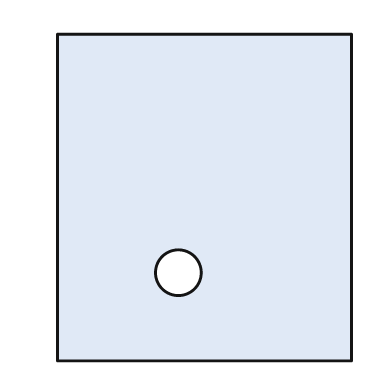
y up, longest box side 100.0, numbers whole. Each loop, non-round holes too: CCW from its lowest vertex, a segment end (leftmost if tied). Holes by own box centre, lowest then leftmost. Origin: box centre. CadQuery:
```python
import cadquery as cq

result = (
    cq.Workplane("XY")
    .moveTo(-45.0, -50.0)
    .lineTo(45.0, -50.0)
    .lineTo(45.0, 50.0)
    .lineTo(-45.0, 50.0)
    .close()
    .moveTo(-8.0, -23.0)
    .circle(7.0)
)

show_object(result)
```